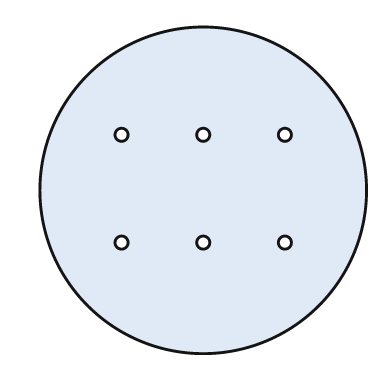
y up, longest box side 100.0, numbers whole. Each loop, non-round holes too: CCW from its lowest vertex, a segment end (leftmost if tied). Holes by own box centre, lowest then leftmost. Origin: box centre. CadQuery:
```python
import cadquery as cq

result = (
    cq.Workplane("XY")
    .moveTo(0.0, 0.0)
    .circle(50.0)
    .moveTo(-25.0, -16.0)
    .circle(2.0)
    .moveTo(0.0, -16.0)
    .circle(2.0)
    .moveTo(25.0, -16.0)
    .circle(2.0)
    .moveTo(-25.0, 17.0)
    .circle(2.0)
    .moveTo(0.0, 17.0)
    .circle(2.0)
    .moveTo(25.0, 17.0)
    .circle(2.0)
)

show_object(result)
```